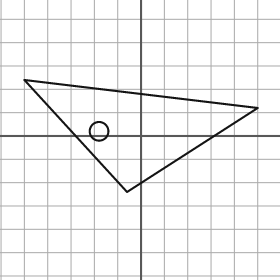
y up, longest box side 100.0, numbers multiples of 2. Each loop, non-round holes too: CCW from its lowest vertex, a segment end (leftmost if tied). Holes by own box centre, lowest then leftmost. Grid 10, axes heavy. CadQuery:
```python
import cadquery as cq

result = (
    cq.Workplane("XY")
    .moveTo(-6.0, -24.0)
    .lineTo(50.0, 12.0)
    .lineTo(-50.0, 24.0)
    .close()
    .moveTo(-18.0, 2.0)
    .circle(4.0)
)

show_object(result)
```